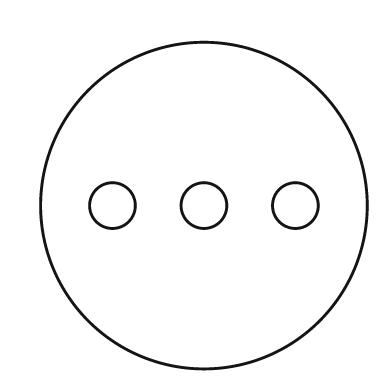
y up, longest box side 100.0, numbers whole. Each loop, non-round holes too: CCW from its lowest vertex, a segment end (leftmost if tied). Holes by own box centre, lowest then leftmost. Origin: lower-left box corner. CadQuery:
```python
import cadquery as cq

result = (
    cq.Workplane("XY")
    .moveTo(50.0, 50.0)
    .circle(50.0)
    .moveTo(22.0, 50.0)
    .circle(7.0)
    .moveTo(50.0, 50.0)
    .circle(7.0)
    .moveTo(78.0, 50.0)
    .circle(7.0)
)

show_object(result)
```